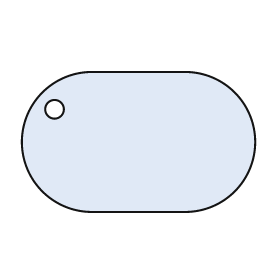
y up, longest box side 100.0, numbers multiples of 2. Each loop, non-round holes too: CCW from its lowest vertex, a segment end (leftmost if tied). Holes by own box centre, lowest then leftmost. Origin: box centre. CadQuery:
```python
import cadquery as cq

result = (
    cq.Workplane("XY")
    .moveTo(-20.0, -30.0)
    .lineTo(20.0, -30.0)
    .threePointArc((50.0, 0.0), (20.0, 30.0))
    .lineTo(-20.0, 30.0)
    .threePointArc((-50.0, 0.0), (-20.0, -30.0))
    .close()
    .moveTo(-36.0, 14.0)
    .circle(4.0)
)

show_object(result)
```